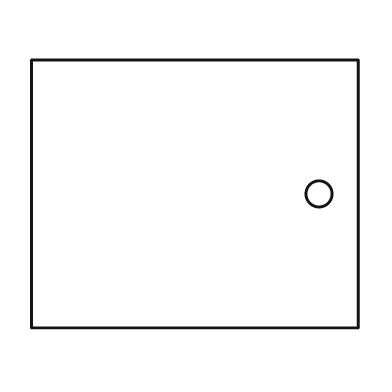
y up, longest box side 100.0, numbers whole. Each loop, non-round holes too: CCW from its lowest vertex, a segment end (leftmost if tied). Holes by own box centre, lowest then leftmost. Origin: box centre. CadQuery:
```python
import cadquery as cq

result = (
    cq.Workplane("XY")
    .moveTo(-50.0, -41.0)
    .lineTo(50.0, -41.0)
    .lineTo(50.0, 41.0)
    .lineTo(-50.0, 41.0)
    .close()
    .moveTo(38.0, 0.0)
    .circle(4.0)
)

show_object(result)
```